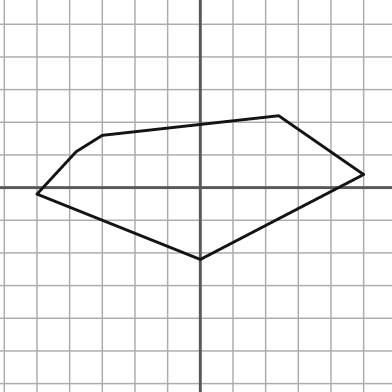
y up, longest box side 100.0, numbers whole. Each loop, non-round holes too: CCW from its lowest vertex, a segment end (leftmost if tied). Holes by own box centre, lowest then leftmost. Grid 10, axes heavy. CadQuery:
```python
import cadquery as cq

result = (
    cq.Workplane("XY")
    .moveTo(0.0, -22.0)
    .lineTo(50.0, 4.0)
    .lineTo(24.0, 22.0)
    .lineTo(-30.0, 16.0)
    .lineTo(-38.0, 11.0)
    .lineTo(-50.0, -2.0)
    .close()
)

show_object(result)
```